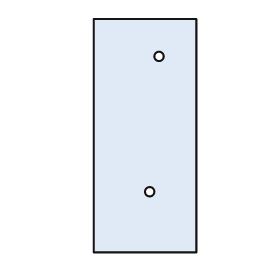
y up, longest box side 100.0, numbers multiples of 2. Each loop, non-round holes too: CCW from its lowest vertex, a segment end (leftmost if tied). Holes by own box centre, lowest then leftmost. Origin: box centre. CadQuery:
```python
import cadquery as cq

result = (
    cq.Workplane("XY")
    .moveTo(-22.0, -50.0)
    .lineTo(22.0, -50.0)
    .lineTo(22.0, 50.0)
    .lineTo(-22.0, 50.0)
    .close()
    .moveTo(2.0, -24.0)
    .circle(2.0)
    .moveTo(6.0, 34.0)
    .circle(2.0)
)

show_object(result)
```